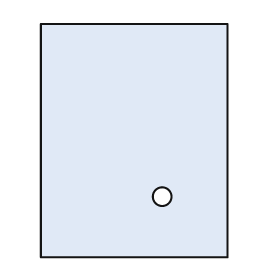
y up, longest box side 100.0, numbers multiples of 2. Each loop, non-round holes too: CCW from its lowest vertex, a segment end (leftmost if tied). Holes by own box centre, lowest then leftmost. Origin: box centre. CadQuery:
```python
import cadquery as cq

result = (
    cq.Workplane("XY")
    .moveTo(-40.0, -50.0)
    .lineTo(40.0, -50.0)
    .lineTo(40.0, 50.0)
    .lineTo(-40.0, 50.0)
    .close()
    .moveTo(12.0, -24.0)
    .circle(4.0)
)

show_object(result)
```